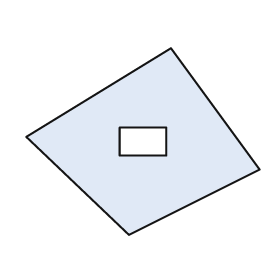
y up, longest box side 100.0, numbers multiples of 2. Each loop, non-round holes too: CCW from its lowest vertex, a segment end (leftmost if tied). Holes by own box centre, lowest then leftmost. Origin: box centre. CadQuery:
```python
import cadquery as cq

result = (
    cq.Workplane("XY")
    .moveTo(-6.0, -40.0)
    .lineTo(50.0, -12.0)
    .lineTo(12.0, 40.0)
    .lineTo(-50.0, 2.0)
    .close()
    .moveTo(-10.0, -6.0)
    .lineTo(10.0, -6.0)
    .lineTo(10.0, 6.0)
    .lineTo(-10.0, 6.0)
    .close()
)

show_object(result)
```